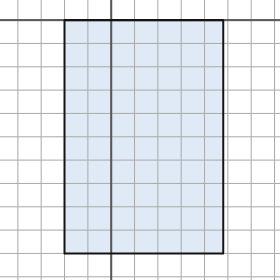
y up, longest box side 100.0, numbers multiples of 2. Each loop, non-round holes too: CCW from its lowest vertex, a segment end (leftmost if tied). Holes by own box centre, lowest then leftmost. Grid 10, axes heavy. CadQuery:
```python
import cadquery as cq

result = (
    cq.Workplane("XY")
    .moveTo(-20.0, -100.0)
    .lineTo(48.0, -100.0)
    .lineTo(48.0, 0.0)
    .lineTo(-20.0, 0.0)
    .close()
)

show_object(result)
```